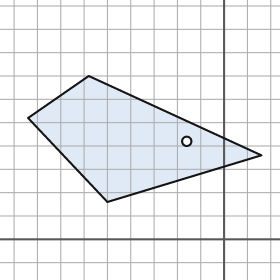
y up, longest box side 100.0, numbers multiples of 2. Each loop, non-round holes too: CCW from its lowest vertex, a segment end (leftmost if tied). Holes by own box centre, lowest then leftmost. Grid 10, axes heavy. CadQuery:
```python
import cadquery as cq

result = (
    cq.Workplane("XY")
    .moveTo(-50.0, 16.0)
    .lineTo(16.0, 36.0)
    .lineTo(-58.0, 70.0)
    .lineTo(-84.0, 52.0)
    .close()
    .moveTo(-16.0, 42.0)
    .circle(2.0)
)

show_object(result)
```